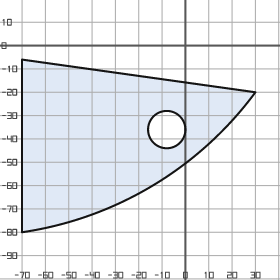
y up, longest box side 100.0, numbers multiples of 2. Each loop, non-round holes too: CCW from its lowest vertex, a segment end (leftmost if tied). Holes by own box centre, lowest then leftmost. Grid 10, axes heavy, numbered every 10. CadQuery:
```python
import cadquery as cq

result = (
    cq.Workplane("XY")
    .moveTo(-70.0, -80.0)
    .threePointArc((-14.0, -60.0), (30.0, -20.0))
    .lineTo(-70.0, -6.0)
    .close()
    .moveTo(-8.0, -36.0)
    .circle(8.0)
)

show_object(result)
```